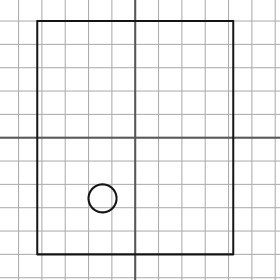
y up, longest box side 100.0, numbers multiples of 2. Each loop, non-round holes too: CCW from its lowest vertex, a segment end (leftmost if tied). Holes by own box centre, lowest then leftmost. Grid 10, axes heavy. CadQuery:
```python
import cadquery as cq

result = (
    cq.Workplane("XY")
    .moveTo(-42.0, -50.0)
    .lineTo(42.0, -50.0)
    .lineTo(42.0, 50.0)
    .lineTo(-42.0, 50.0)
    .close()
    .moveTo(-14.0, -26.0)
    .circle(6.0)
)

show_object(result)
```